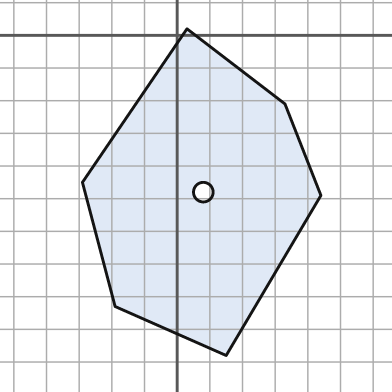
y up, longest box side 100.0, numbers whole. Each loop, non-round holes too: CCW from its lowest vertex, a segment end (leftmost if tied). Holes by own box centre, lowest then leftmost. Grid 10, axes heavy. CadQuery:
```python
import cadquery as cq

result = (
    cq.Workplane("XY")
    .moveTo(15.0, -98.0)
    .lineTo(44.0, -49.0)
    .lineTo(33.0, -21.0)
    .lineTo(3.0, 2.0)
    .lineTo(-29.0, -45.0)
    .lineTo(-19.0, -83.0)
    .close()
    .moveTo(8.0, -48.0)
    .circle(3.0)
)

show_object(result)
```